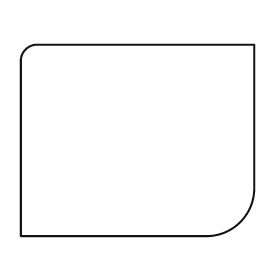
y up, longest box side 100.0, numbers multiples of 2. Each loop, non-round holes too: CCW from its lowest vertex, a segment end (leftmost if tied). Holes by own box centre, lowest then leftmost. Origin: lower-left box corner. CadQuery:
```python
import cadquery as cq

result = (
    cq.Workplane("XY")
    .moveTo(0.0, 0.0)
    .lineTo(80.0, 0.0)
    .threePointArc((94.0, 6.0), (100.0, 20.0))
    .lineTo(100.0, 82.0)
    .lineTo(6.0, 82.0)
    .threePointArc((2.0, 80.0), (0.0, 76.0))
    .close()
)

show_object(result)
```